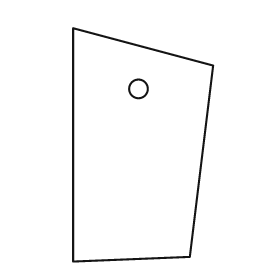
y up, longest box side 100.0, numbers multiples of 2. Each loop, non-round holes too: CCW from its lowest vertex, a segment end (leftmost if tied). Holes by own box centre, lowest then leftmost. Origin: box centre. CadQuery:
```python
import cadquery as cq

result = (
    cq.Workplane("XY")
    .moveTo(-30.0, -50.0)
    .lineTo(20.0, -48.0)
    .lineTo(30.0, 34.0)
    .lineTo(-30.0, 50.0)
    .close()
    .moveTo(-2.0, 24.0)
    .circle(4.0)
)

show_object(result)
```